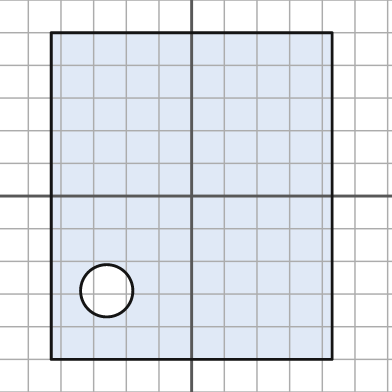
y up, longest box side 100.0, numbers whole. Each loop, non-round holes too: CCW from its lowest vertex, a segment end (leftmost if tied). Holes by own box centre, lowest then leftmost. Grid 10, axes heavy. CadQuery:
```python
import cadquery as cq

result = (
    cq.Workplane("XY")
    .moveTo(-43.0, -50.0)
    .lineTo(43.0, -50.0)
    .lineTo(43.0, 50.0)
    .lineTo(-43.0, 50.0)
    .close()
    .moveTo(-26.0, -29.0)
    .circle(8.0)
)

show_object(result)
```